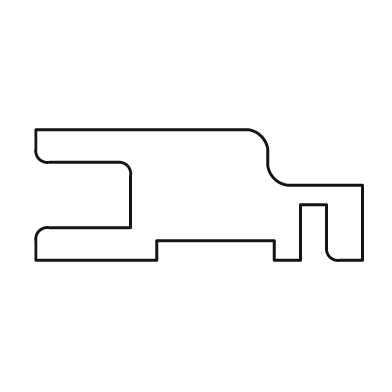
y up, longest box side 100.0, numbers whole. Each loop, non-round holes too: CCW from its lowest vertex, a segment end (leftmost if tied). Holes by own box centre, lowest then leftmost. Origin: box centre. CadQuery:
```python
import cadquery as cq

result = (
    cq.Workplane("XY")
    .moveTo(-50.0, -20.0)
    .lineTo(-13.0, -20.0)
    .lineTo(-13.0, -14.0)
    .lineTo(23.0, -14.0)
    .lineTo(23.0, -20.0)
    .lineTo(31.0, -20.0)
    .lineTo(31.0, -3.0)
    .lineTo(39.0, -3.0)
    .lineTo(39.0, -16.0)
    .threePointArc((40.0, -19.0), (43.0, -20.0))
    .lineTo(50.0, -20.0)
    .lineTo(50.0, 3.0)
    .lineTo(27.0, 3.0)
    .threePointArc((23.0, 5.0), (21.0, 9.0))
    .lineTo(21.0, 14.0)
    .threePointArc((19.0, 18.0), (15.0, 20.0))
    .lineTo(-50.0, 20.0)
    .lineTo(-50.0, 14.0)
    .threePointArc((-49.0, 11.0), (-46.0, 10.0))
    .lineTo(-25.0, 10.0)
    .threePointArc((-22.0, 9.0), (-21.0, 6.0))
    .lineTo(-21.0, -10.0)
    .lineTo(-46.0, -10.0)
    .threePointArc((-49.0, -11.0), (-50.0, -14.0))
    .close()
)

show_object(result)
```